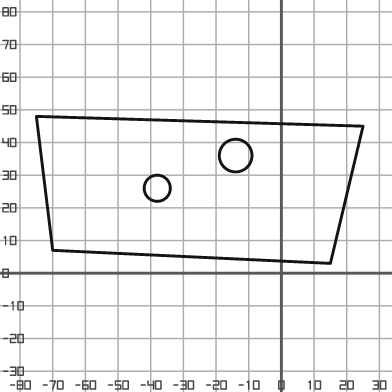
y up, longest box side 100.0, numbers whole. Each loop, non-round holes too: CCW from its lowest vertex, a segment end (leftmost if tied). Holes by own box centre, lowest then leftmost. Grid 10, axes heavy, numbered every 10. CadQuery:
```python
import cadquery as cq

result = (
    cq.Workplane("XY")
    .moveTo(15.0, 3.0)
    .lineTo(25.0, 45.0)
    .lineTo(-75.0, 48.0)
    .lineTo(-70.0, 7.0)
    .close()
    .moveTo(-38.0, 26.0)
    .circle(4.0)
    .moveTo(-14.0, 36.0)
    .circle(5.0)
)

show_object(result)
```